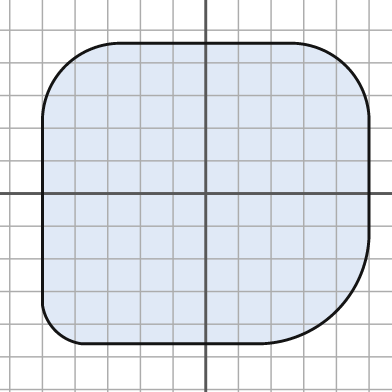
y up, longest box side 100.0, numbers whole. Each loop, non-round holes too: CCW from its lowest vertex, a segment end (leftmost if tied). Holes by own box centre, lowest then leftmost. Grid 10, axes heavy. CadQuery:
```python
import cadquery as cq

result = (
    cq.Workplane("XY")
    .moveTo(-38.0, -46.0)
    .lineTo(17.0, -46.0)
    .threePointArc((40.0, -36.0), (50.0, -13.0))
    .lineTo(50.0, 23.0)
    .threePointArc((43.0, 39.0), (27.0, 46.0))
    .lineTo(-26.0, 46.0)
    .threePointArc((-43.0, 39.0), (-50.0, 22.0))
    .lineTo(-50.0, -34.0)
    .threePointArc((-46.0, -42.0), (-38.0, -46.0))
    .close()
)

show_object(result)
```